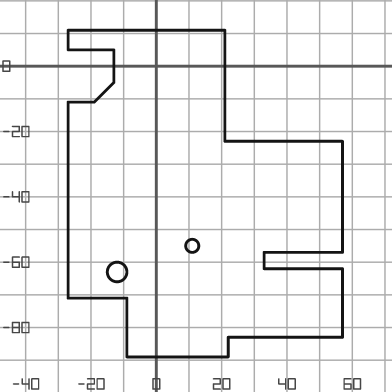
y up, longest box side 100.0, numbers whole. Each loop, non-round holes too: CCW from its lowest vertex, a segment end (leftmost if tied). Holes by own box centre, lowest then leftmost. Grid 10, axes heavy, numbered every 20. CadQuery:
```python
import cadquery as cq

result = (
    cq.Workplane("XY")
    .moveTo(-9.0, -89.0)
    .lineTo(22.0, -89.0)
    .lineTo(22.0, -83.0)
    .lineTo(57.0, -83.0)
    .lineTo(57.0, -62.0)
    .lineTo(33.0, -62.0)
    .lineTo(33.0, -57.0)
    .lineTo(57.0, -57.0)
    .lineTo(57.0, -23.0)
    .lineTo(21.0, -23.0)
    .lineTo(21.0, 11.0)
    .lineTo(-27.0, 11.0)
    .lineTo(-27.0, 5.0)
    .lineTo(-13.0, 5.0)
    .lineTo(-13.0, -5.0)
    .lineTo(-19.0, -11.0)
    .lineTo(-27.0, -11.0)
    .lineTo(-27.0, -71.0)
    .lineTo(-9.0, -71.0)
    .close()
    .moveTo(-12.0, -63.0)
    .circle(3.0)
    .moveTo(11.0, -55.0)
    .circle(2.0)
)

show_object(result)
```